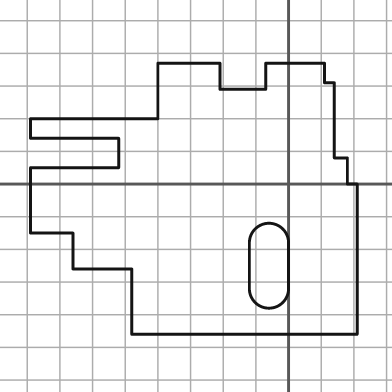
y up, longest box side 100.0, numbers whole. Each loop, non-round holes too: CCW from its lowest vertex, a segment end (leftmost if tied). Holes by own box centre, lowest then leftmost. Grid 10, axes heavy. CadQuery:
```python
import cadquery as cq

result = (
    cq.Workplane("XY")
    .moveTo(-48.0, -46.0)
    .lineTo(21.0, -46.0)
    .lineTo(21.0, 0.0)
    .lineTo(18.0, 0.0)
    .lineTo(18.0, 8.0)
    .lineTo(14.0, 8.0)
    .lineTo(14.0, 31.0)
    .lineTo(11.0, 31.0)
    .lineTo(11.0, 37.0)
    .lineTo(-7.0, 37.0)
    .lineTo(-7.0, 29.0)
    .lineTo(-21.0, 29.0)
    .lineTo(-21.0, 37.0)
    .lineTo(-40.0, 37.0)
    .lineTo(-40.0, 20.0)
    .lineTo(-79.0, 20.0)
    .lineTo(-79.0, 14.0)
    .lineTo(-52.0, 14.0)
    .lineTo(-52.0, 5.0)
    .lineTo(-79.0, 5.0)
    .lineTo(-79.0, -15.0)
    .lineTo(-66.0, -15.0)
    .lineTo(-66.0, -26.0)
    .lineTo(-48.0, -26.0)
    .close()
    .moveTo(-12.0, -32.0)
    .threePointArc((-6.0, -38.0), (0.0, -32.0))
    .lineTo(0.0, -18.0)
    .threePointArc((-6.0, -12.0), (-12.0, -18.0))
    .close()
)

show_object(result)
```